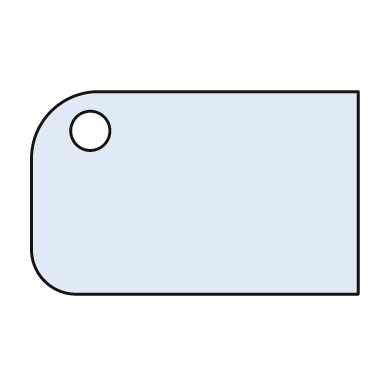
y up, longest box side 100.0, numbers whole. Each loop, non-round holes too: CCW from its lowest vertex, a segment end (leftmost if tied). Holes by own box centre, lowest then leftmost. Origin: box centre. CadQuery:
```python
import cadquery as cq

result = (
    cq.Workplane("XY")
    .moveTo(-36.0, -31.0)
    .lineTo(50.0, -31.0)
    .lineTo(50.0, 31.0)
    .lineTo(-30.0, 31.0)
    .threePointArc((-44.0, 25.0), (-50.0, 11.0))
    .lineTo(-50.0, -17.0)
    .threePointArc((-46.0, -27.0), (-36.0, -31.0))
    .close()
    .moveTo(-32.0, 19.0)
    .circle(6.0)
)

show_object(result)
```